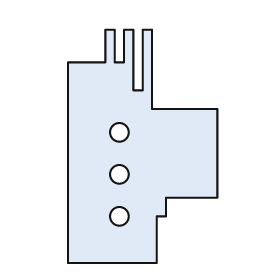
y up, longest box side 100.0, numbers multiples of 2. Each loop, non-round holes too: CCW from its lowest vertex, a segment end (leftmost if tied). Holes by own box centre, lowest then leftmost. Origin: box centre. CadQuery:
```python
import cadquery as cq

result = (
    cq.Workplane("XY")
    .moveTo(-32.0, -50.0)
    .lineTo(6.0, -50.0)
    .lineTo(6.0, -30.0)
    .lineTo(10.0, -30.0)
    .lineTo(10.0, -22.0)
    .lineTo(32.0, -22.0)
    .lineTo(32.0, 16.0)
    .lineTo(4.0, 16.0)
    .lineTo(4.0, 50.0)
    .lineTo(0.0, 50.0)
    .lineTo(0.0, 24.0)
    .lineTo(-4.0, 24.0)
    .lineTo(-4.0, 50.0)
    .lineTo(-8.0, 50.0)
    .lineTo(-8.0, 36.0)
    .lineTo(-12.0, 36.0)
    .lineTo(-12.0, 50.0)
    .lineTo(-16.0, 50.0)
    .lineTo(-16.0, 36.0)
    .lineTo(-32.0, 36.0)
    .close()
    .moveTo(-10.0, -30.0)
    .circle(4.0)
    .moveTo(-10.0, -12.0)
    .circle(4.0)
    .moveTo(-10.0, 6.0)
    .circle(4.0)
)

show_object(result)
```